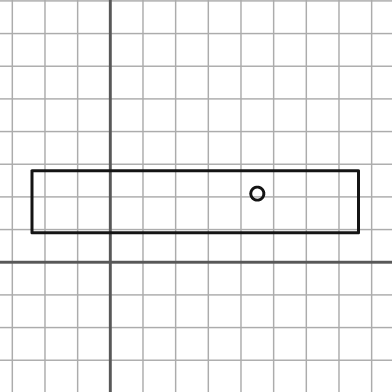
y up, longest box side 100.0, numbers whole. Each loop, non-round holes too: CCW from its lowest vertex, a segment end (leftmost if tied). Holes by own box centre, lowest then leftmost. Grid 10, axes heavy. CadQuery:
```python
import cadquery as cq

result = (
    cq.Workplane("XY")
    .moveTo(-24.0, 9.0)
    .lineTo(76.0, 9.0)
    .lineTo(76.0, 28.0)
    .lineTo(-24.0, 28.0)
    .close()
    .moveTo(45.0, 21.0)
    .circle(2.0)
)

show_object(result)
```